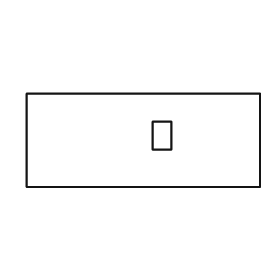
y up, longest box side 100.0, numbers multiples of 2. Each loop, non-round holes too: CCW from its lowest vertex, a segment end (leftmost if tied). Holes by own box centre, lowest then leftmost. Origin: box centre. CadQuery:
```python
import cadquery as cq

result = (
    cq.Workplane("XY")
    .moveTo(-50.0, -20.0)
    .lineTo(50.0, -20.0)
    .lineTo(50.0, 20.0)
    .lineTo(-50.0, 20.0)
    .close()
    .moveTo(4.0, -4.0)
    .lineTo(12.0, -4.0)
    .lineTo(12.0, 8.0)
    .lineTo(4.0, 8.0)
    .close()
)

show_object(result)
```